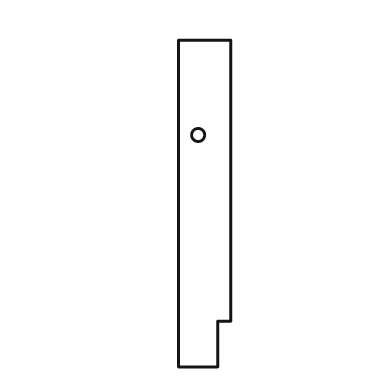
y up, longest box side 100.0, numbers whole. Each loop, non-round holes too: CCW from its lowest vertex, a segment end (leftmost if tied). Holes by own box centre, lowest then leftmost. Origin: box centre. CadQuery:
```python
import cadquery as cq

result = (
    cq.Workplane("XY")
    .moveTo(-8.0, -50.0)
    .lineTo(4.0, -50.0)
    .lineTo(4.0, -36.0)
    .lineTo(8.0, -36.0)
    .lineTo(8.0, 50.0)
    .lineTo(-8.0, 50.0)
    .close()
    .moveTo(-2.0, 21.0)
    .circle(2.0)
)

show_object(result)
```